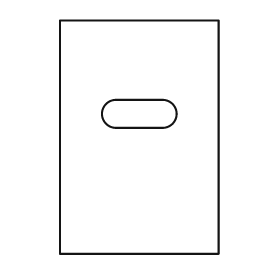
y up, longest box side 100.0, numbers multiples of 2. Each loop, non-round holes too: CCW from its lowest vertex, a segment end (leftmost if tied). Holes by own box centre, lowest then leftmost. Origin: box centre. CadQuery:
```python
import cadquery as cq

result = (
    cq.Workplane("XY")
    .moveTo(-34.0, -50.0)
    .lineTo(34.0, -50.0)
    .lineTo(34.0, 50.0)
    .lineTo(-34.0, 50.0)
    .close()
    .moveTo(-10.0, 4.0)
    .lineTo(10.0, 4.0)
    .threePointArc((16.0, 10.0), (10.0, 16.0))
    .lineTo(-10.0, 16.0)
    .threePointArc((-16.0, 10.0), (-10.0, 4.0))
    .close()
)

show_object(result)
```